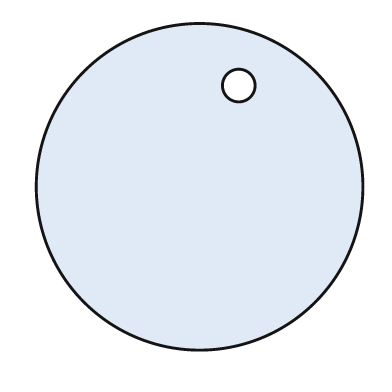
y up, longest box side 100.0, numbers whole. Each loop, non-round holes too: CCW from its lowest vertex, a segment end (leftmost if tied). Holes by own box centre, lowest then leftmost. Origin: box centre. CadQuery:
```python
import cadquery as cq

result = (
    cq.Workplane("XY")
    .moveTo(0.0, 0.0)
    .circle(50.0)
    .moveTo(12.0, 31.0)
    .circle(5.0)
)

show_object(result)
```